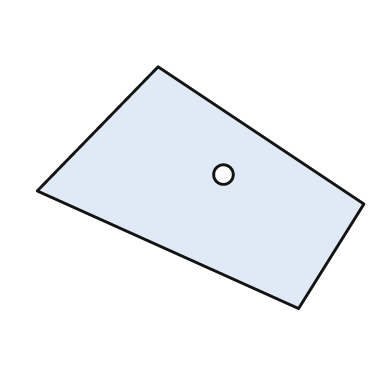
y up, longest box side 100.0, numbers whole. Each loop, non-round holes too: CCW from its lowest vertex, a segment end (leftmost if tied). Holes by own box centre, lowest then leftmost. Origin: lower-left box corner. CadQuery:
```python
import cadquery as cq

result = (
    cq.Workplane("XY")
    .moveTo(80.0, 0.0)
    .lineTo(100.0, 32.0)
    .lineTo(37.0, 74.0)
    .lineTo(0.0, 36.0)
    .close()
    .moveTo(57.0, 41.0)
    .circle(3.0)
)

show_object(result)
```